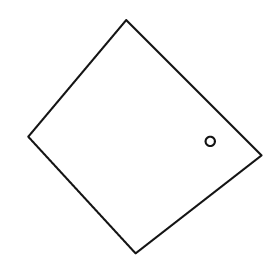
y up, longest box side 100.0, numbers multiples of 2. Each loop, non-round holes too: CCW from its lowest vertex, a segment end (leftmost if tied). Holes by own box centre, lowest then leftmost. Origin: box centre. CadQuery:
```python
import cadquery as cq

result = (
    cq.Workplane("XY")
    .moveTo(-4.0, -50.0)
    .lineTo(50.0, -8.0)
    .lineTo(-8.0, 50.0)
    .lineTo(-50.0, 0.0)
    .close()
    .moveTo(28.0, -2.0)
    .circle(2.0)
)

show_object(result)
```